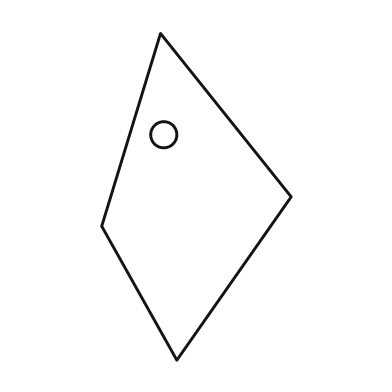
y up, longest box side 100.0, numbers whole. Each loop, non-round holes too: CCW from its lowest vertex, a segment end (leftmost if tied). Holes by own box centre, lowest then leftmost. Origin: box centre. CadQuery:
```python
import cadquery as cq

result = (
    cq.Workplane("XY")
    .moveTo(-6.0, -50.0)
    .lineTo(29.0, 0.0)
    .lineTo(-11.0, 50.0)
    .lineTo(-29.0, -9.0)
    .close()
    .moveTo(-10.0, 19.0)
    .circle(4.0)
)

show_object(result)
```